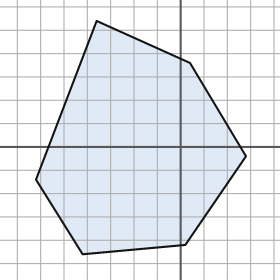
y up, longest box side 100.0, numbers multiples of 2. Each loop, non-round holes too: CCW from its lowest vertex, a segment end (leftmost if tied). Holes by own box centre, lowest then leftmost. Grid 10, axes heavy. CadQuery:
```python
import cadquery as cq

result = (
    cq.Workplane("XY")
    .moveTo(-42.0, -46.0)
    .lineTo(2.0, -42.0)
    .lineTo(28.0, -4.0)
    .lineTo(4.0, 36.0)
    .lineTo(-36.0, 54.0)
    .lineTo(-62.0, -14.0)
    .close()
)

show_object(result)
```